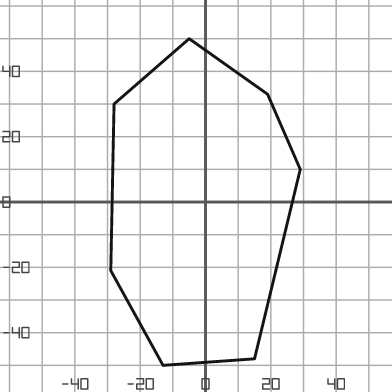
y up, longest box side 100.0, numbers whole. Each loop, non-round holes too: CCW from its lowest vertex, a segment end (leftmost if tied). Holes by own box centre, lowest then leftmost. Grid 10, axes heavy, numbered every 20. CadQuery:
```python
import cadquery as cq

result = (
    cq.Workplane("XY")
    .moveTo(-13.0, -50.0)
    .lineTo(15.0, -48.0)
    .lineTo(29.0, 10.0)
    .lineTo(19.0, 33.0)
    .lineTo(-5.0, 50.0)
    .lineTo(-28.0, 30.0)
    .lineTo(-29.0, -21.0)
    .close()
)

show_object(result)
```